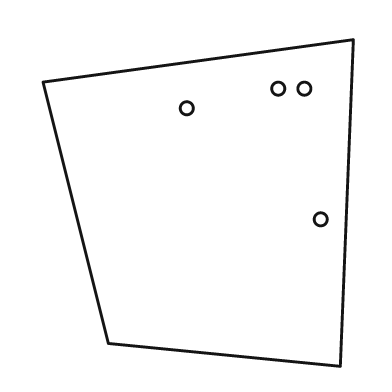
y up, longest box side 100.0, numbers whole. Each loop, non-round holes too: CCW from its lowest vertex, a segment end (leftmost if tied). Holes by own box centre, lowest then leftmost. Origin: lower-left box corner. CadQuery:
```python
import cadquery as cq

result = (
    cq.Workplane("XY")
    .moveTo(91.0, 0.0)
    .lineTo(95.0, 100.0)
    .lineTo(0.0, 87.0)
    .lineTo(20.0, 7.0)
    .close()
    .moveTo(85.0, 45.0)
    .circle(2.0)
    .moveTo(44.0, 79.0)
    .circle(2.0)
    .moveTo(72.0, 85.0)
    .circle(2.0)
    .moveTo(80.0, 85.0)
    .circle(2.0)
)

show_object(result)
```